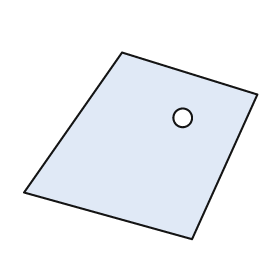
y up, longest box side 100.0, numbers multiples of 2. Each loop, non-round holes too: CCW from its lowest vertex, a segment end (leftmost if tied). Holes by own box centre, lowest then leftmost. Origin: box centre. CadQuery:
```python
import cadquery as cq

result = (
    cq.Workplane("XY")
    .moveTo(22.0, -40.0)
    .lineTo(50.0, 22.0)
    .lineTo(-8.0, 40.0)
    .lineTo(-50.0, -20.0)
    .close()
    .moveTo(18.0, 12.0)
    .circle(4.0)
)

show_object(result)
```